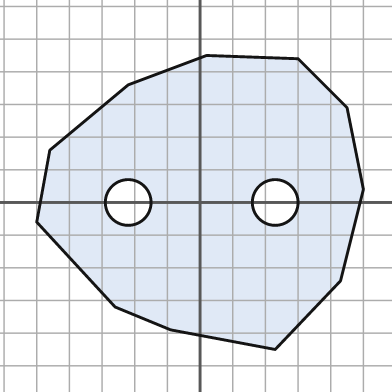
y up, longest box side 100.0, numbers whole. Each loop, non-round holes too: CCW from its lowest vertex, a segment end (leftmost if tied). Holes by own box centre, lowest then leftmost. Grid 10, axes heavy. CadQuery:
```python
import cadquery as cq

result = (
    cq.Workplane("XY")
    .moveTo(23.0, -45.0)
    .lineTo(43.0, -24.0)
    .lineTo(50.0, 4.0)
    .lineTo(45.0, 29.0)
    .lineTo(30.0, 44.0)
    .lineTo(2.0, 45.0)
    .lineTo(-22.0, 36.0)
    .lineTo(-46.0, 16.0)
    .lineTo(-50.0, -6.0)
    .lineTo(-26.0, -32.0)
    .lineTo(-9.0, -39.0)
    .close()
    .moveTo(-22.0, 0.0)
    .circle(7.0)
    .moveTo(23.0, 0.0)
    .circle(7.0)
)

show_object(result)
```